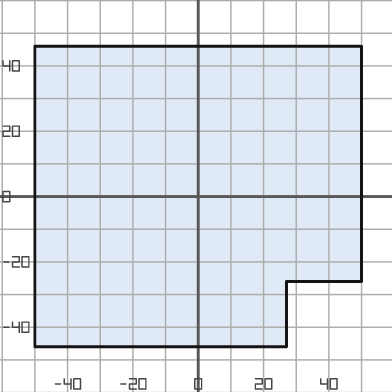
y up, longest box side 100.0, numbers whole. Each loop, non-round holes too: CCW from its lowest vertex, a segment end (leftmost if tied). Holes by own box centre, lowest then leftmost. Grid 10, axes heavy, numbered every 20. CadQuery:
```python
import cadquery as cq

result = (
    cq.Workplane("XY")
    .moveTo(-50.0, -46.0)
    .lineTo(27.0, -46.0)
    .lineTo(27.0, -26.0)
    .lineTo(50.0, -26.0)
    .lineTo(50.0, 46.0)
    .lineTo(-50.0, 46.0)
    .close()
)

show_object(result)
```